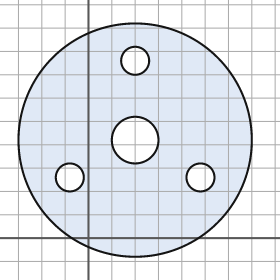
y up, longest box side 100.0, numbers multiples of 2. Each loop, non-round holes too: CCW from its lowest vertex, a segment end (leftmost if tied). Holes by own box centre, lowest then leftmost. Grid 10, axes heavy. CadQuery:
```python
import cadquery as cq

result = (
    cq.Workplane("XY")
    .moveTo(20.0, 42.0)
    .circle(50.0)
    .moveTo(-8.0, 26.0)
    .circle(6.0)
    .moveTo(48.0, 26.0)
    .circle(6.0)
    .moveTo(20.0, 42.0)
    .circle(10.0)
    .moveTo(20.0, 76.0)
    .circle(6.0)
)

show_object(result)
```